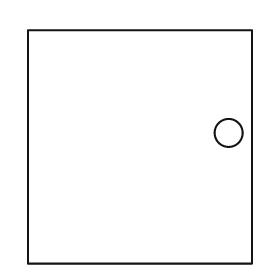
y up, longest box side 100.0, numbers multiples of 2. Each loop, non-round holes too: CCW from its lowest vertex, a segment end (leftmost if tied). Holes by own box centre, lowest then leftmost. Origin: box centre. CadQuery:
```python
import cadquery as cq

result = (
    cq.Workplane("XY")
    .moveTo(-48.0, -50.0)
    .lineTo(48.0, -50.0)
    .lineTo(48.0, 50.0)
    .lineTo(-48.0, 50.0)
    .close()
    .moveTo(38.0, 6.0)
    .circle(6.0)
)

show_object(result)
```